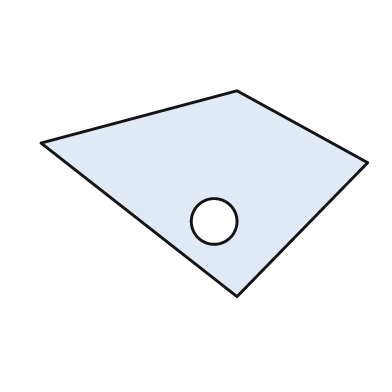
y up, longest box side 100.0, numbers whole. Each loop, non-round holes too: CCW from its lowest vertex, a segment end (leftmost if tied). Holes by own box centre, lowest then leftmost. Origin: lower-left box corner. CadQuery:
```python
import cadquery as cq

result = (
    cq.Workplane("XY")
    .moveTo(60.0, 0.0)
    .lineTo(100.0, 41.0)
    .lineTo(60.0, 63.0)
    .lineTo(0.0, 47.0)
    .close()
    .moveTo(53.0, 23.0)
    .circle(7.0)
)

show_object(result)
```